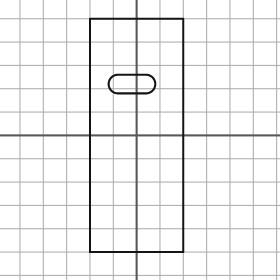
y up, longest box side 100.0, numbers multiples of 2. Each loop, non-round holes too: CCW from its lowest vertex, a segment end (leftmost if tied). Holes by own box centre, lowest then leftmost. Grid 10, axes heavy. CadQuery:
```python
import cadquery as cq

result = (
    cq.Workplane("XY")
    .moveTo(-20.0, -50.0)
    .lineTo(20.0, -50.0)
    .lineTo(20.0, 50.0)
    .lineTo(-20.0, 50.0)
    .close()
    .moveTo(-8.0, 18.0)
    .lineTo(4.0, 18.0)
    .threePointArc((8.0, 22.0), (4.0, 26.0))
    .lineTo(-8.0, 26.0)
    .threePointArc((-12.0, 22.0), (-8.0, 18.0))
    .close()
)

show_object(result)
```